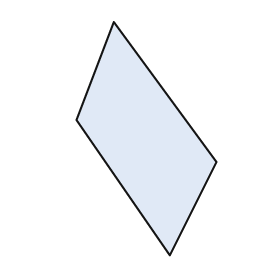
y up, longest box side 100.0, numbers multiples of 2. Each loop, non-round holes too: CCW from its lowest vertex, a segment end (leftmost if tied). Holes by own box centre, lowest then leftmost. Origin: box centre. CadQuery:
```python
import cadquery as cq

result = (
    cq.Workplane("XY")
    .moveTo(10.0, -50.0)
    .lineTo(30.0, -10.0)
    .lineTo(-14.0, 50.0)
    .lineTo(-30.0, 8.0)
    .close()
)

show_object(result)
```